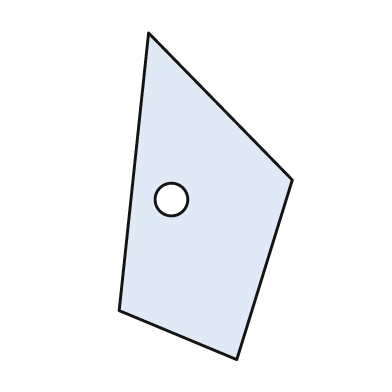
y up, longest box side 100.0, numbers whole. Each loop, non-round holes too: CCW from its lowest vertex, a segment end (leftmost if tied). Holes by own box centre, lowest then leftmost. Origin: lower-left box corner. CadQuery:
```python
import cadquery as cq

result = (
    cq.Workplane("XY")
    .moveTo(36.0, 0.0)
    .lineTo(53.0, 55.0)
    .lineTo(9.0, 100.0)
    .lineTo(0.0, 15.0)
    .close()
    .moveTo(16.0, 49.0)
    .circle(5.0)
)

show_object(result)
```